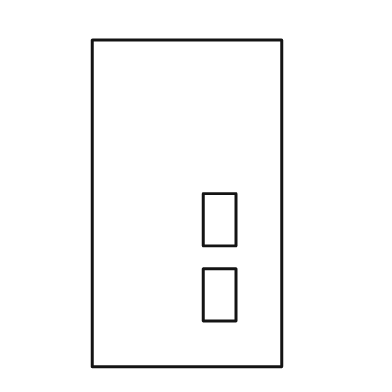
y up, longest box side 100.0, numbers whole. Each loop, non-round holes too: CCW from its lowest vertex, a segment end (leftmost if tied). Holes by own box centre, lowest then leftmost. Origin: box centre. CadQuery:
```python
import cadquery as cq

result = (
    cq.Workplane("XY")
    .moveTo(-29.0, -50.0)
    .lineTo(29.0, -50.0)
    .lineTo(29.0, 50.0)
    .lineTo(-29.0, 50.0)
    .close()
    .moveTo(5.0, -36.0)
    .lineTo(15.0, -36.0)
    .lineTo(15.0, -20.0)
    .lineTo(5.0, -20.0)
    .close()
    .moveTo(5.0, -13.0)
    .lineTo(15.0, -13.0)
    .lineTo(15.0, 3.0)
    .lineTo(5.0, 3.0)
    .close()
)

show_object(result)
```